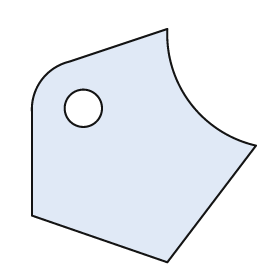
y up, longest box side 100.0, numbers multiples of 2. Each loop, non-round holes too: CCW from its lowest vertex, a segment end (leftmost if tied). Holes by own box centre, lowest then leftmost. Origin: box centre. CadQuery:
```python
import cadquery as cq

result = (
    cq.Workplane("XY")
    .moveTo(10.0, -50.0)
    .lineTo(48.0, 0.0)
    .threePointArc((20.0, 18.0), (10.0, 50.0))
    .lineTo(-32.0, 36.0)
    .threePointArc((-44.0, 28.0), (-48.0, 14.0))
    .lineTo(-48.0, -30.0)
    .close()
    .moveTo(-26.0, 16.0)
    .circle(8.0)
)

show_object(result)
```